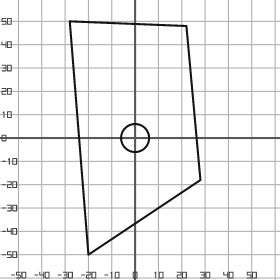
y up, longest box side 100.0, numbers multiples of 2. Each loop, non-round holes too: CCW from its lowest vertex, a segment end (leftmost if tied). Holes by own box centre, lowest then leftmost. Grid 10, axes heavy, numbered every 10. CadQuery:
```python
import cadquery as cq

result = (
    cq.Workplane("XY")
    .moveTo(-20.0, -50.0)
    .lineTo(28.0, -18.0)
    .lineTo(22.0, 48.0)
    .lineTo(-28.0, 50.0)
    .close()
    .moveTo(0.0, 0.0)
    .circle(6.0)
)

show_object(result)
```